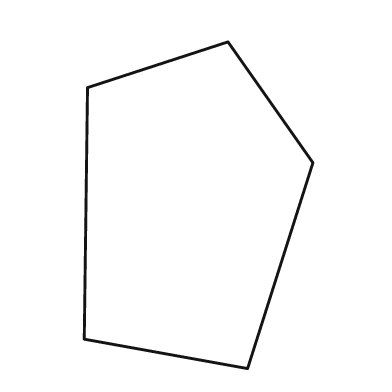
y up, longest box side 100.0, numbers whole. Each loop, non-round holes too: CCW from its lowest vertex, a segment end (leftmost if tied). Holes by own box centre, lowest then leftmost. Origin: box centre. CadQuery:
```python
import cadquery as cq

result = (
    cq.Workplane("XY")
    .moveTo(15.0, -50.0)
    .lineTo(35.0, 13.0)
    .lineTo(9.0, 50.0)
    .lineTo(-34.0, 36.0)
    .lineTo(-35.0, -41.0)
    .close()
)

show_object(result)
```